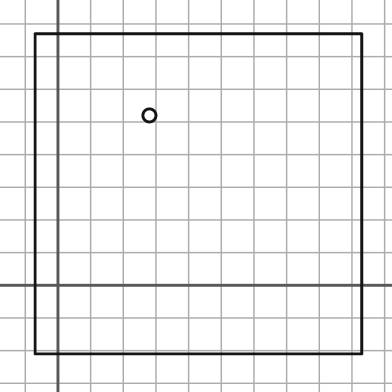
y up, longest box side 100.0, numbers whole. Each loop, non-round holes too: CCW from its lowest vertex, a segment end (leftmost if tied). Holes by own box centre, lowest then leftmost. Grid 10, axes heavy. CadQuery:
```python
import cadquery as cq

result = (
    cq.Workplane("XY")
    .moveTo(-7.0, -21.0)
    .lineTo(93.0, -21.0)
    .lineTo(93.0, 77.0)
    .lineTo(-7.0, 77.0)
    .close()
    .moveTo(28.0, 52.0)
    .circle(2.0)
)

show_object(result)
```